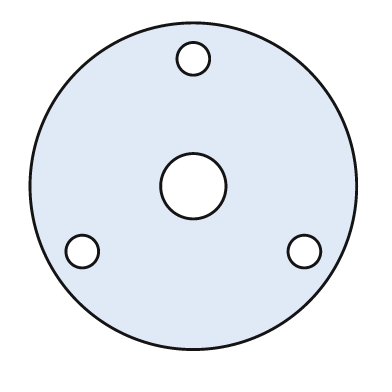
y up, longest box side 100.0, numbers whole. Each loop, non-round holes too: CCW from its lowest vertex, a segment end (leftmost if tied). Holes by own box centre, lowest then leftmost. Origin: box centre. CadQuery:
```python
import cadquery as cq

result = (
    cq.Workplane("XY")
    .moveTo(0.0, 0.0)
    .circle(50.0)
    .moveTo(-34.0, -20.0)
    .circle(5.0)
    .moveTo(34.0, -20.0)
    .circle(5.0)
    .moveTo(0.0, 0.0)
    .circle(10.0)
    .moveTo(0.0, 39.0)
    .circle(5.0)
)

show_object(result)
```